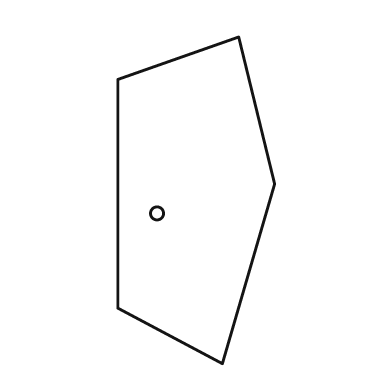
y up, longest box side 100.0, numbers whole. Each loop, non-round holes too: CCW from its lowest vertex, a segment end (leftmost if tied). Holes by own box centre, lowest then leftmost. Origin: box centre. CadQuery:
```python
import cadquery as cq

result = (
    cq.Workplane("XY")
    .moveTo(8.0, -50.0)
    .lineTo(24.0, 5.0)
    .lineTo(13.0, 50.0)
    .lineTo(-24.0, 37.0)
    .lineTo(-24.0, -33.0)
    .close()
    .moveTo(-12.0, -4.0)
    .circle(2.0)
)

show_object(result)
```